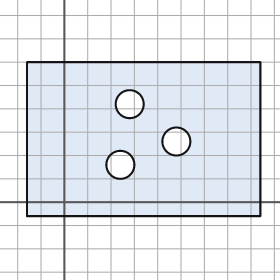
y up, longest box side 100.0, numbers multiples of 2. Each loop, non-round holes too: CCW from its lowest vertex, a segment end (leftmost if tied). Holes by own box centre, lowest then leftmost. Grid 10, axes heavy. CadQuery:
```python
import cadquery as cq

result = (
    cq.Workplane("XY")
    .moveTo(-16.0, -6.0)
    .lineTo(84.0, -6.0)
    .lineTo(84.0, 60.0)
    .lineTo(-16.0, 60.0)
    .close()
    .moveTo(24.0, 16.0)
    .circle(6.0)
    .moveTo(48.0, 26.0)
    .circle(6.0)
    .moveTo(28.0, 42.0)
    .circle(6.0)
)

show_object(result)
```